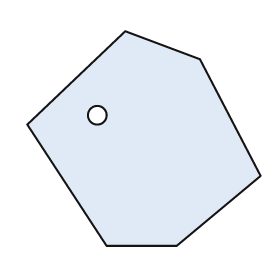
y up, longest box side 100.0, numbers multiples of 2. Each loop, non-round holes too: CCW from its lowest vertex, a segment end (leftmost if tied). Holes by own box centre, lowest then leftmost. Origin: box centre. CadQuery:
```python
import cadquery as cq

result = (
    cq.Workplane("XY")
    .moveTo(-16.0, -46.0)
    .lineTo(14.0, -46.0)
    .lineTo(50.0, -16.0)
    .lineTo(24.0, 34.0)
    .lineTo(-8.0, 46.0)
    .lineTo(-50.0, 6.0)
    .close()
    .moveTo(-20.0, 10.0)
    .circle(4.0)
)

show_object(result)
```